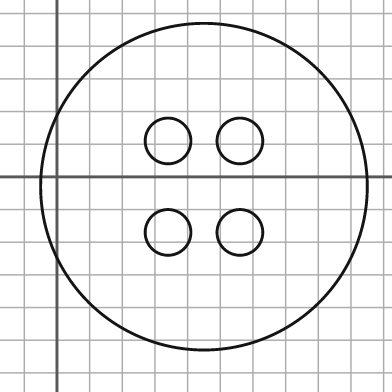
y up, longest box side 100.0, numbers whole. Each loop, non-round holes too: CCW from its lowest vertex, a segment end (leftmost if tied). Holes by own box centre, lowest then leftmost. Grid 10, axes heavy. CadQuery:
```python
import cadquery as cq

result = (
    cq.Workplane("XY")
    .moveTo(45.0, -3.0)
    .circle(50.0)
    .moveTo(34.0, -17.0)
    .circle(7.0)
    .moveTo(56.0, -17.0)
    .circle(7.0)
    .moveTo(34.0, 11.0)
    .circle(7.0)
    .moveTo(56.0, 11.0)
    .circle(7.0)
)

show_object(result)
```